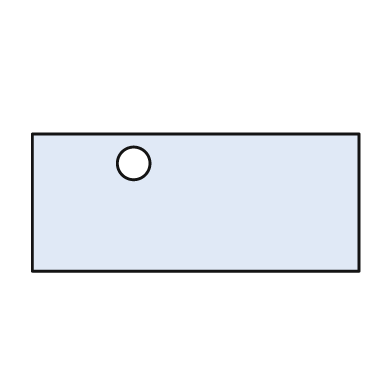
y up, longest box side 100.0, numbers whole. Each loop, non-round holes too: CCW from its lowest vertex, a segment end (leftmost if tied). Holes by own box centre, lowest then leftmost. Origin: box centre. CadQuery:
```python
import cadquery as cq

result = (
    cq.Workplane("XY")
    .moveTo(-50.0, -21.0)
    .lineTo(50.0, -21.0)
    .lineTo(50.0, 21.0)
    .lineTo(-50.0, 21.0)
    .close()
    .moveTo(-19.0, 12.0)
    .circle(5.0)
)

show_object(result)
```